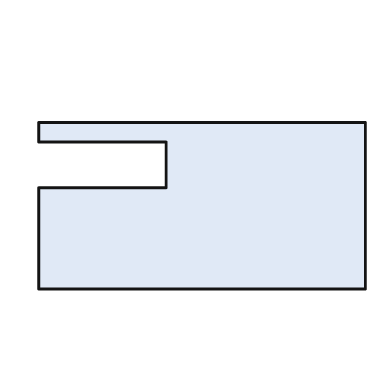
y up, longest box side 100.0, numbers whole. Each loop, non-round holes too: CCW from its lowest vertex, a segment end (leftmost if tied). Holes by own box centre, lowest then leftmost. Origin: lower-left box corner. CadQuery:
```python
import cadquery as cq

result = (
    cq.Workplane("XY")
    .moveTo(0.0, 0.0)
    .lineTo(100.0, 0.0)
    .lineTo(100.0, 51.0)
    .lineTo(0.0, 51.0)
    .lineTo(0.0, 45.0)
    .lineTo(39.0, 45.0)
    .lineTo(39.0, 31.0)
    .lineTo(0.0, 31.0)
    .close()
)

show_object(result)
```